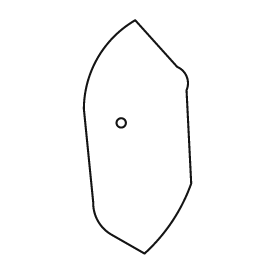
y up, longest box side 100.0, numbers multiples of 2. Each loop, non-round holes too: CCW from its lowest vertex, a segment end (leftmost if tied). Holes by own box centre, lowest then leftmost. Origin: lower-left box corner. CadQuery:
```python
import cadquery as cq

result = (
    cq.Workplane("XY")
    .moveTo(26.0, 0.0)
    .threePointArc((38.0, 14.0), (46.0, 30.0))
    .lineTo(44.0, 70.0)
    .threePointArc((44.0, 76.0), (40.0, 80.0))
    .lineTo(22.0, 100.0)
    .threePointArc((6.0, 84.0), (0.0, 62.0))
    .lineTo(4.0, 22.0)
    .threePointArc((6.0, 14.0), (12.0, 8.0))
    .close()
    .moveTo(16.0, 56.0)
    .circle(2.0)
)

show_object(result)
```